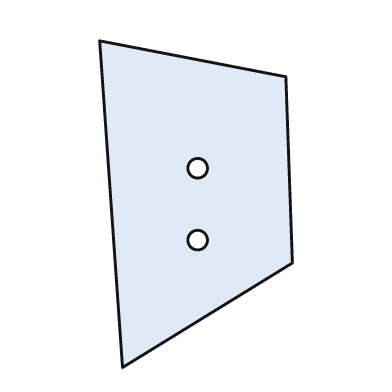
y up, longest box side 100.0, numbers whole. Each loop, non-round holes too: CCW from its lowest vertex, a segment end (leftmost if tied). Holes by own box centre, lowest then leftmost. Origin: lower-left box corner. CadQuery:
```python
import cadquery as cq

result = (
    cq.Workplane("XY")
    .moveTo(7.0, 0.0)
    .lineTo(59.0, 32.0)
    .lineTo(57.0, 89.0)
    .lineTo(0.0, 100.0)
    .close()
    .moveTo(30.0, 39.0)
    .circle(3.0)
    .moveTo(30.0, 61.0)
    .circle(3.0)
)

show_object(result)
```